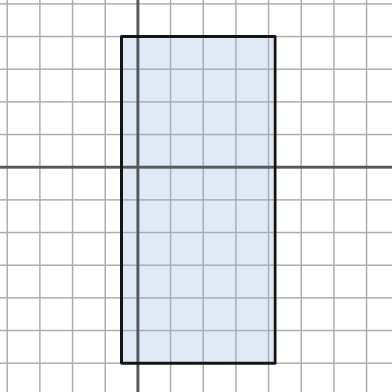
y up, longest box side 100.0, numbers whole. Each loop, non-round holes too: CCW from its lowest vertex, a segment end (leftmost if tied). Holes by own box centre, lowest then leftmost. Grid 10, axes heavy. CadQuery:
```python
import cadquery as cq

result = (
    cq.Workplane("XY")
    .moveTo(-5.0, -60.0)
    .lineTo(42.0, -60.0)
    .lineTo(42.0, 40.0)
    .lineTo(-5.0, 40.0)
    .close()
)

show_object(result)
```